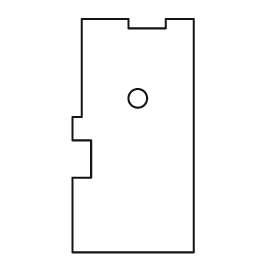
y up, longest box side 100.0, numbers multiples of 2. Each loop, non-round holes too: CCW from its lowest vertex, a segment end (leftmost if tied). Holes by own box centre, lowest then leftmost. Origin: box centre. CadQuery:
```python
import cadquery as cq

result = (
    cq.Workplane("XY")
    .moveTo(-26.0, -50.0)
    .lineTo(26.0, -50.0)
    .lineTo(26.0, 50.0)
    .lineTo(14.0, 50.0)
    .lineTo(14.0, 46.0)
    .lineTo(-2.0, 46.0)
    .lineTo(-2.0, 50.0)
    .lineTo(-22.0, 50.0)
    .lineTo(-22.0, 8.0)
    .lineTo(-26.0, 8.0)
    .lineTo(-26.0, -2.0)
    .lineTo(-18.0, -2.0)
    .lineTo(-18.0, -18.0)
    .lineTo(-26.0, -18.0)
    .close()
    .moveTo(2.0, 16.0)
    .circle(4.0)
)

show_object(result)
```